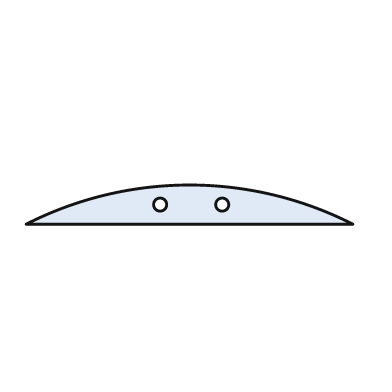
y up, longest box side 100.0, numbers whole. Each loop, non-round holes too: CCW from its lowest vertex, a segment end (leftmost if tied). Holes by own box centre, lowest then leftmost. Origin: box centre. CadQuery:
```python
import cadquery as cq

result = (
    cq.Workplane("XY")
    .moveTo(-50.0, -6.0)
    .lineTo(50.0, -6.0)
    .threePointArc((0.0, 6.0), (-50.0, -6.0))
    .close()
    .moveTo(-9.0, 0.0)
    .circle(2.0)
    .moveTo(10.0, 0.0)
    .circle(2.0)
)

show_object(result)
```